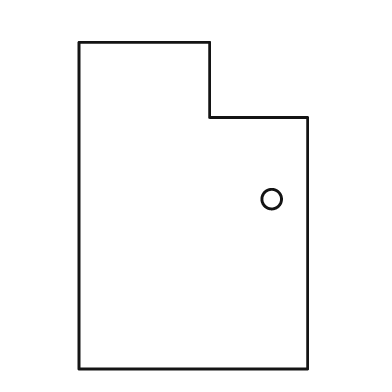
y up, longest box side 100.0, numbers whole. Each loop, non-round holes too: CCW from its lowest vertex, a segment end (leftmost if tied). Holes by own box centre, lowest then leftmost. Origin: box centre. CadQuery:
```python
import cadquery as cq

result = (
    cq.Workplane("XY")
    .moveTo(-35.0, -50.0)
    .lineTo(35.0, -50.0)
    .lineTo(35.0, 27.0)
    .lineTo(5.0, 27.0)
    .lineTo(5.0, 50.0)
    .lineTo(-35.0, 50.0)
    .close()
    .moveTo(24.0, 2.0)
    .circle(3.0)
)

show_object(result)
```